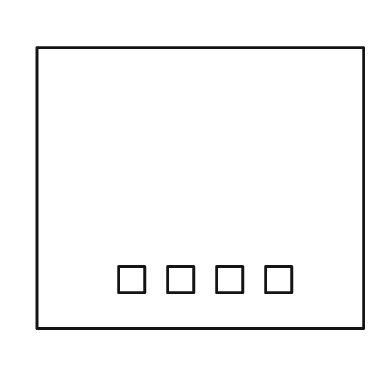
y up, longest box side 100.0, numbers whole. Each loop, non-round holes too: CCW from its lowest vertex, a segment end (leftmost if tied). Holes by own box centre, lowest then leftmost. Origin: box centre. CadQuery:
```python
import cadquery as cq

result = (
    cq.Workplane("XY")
    .moveTo(-50.0, -43.0)
    .lineTo(50.0, -43.0)
    .lineTo(50.0, 43.0)
    .lineTo(-50.0, 43.0)
    .close()
    .moveTo(-25.0, -32.0)
    .lineTo(-17.0, -32.0)
    .lineTo(-17.0, -24.0)
    .lineTo(-25.0, -24.0)
    .close()
    .moveTo(-10.0, -32.0)
    .lineTo(-2.0, -32.0)
    .lineTo(-2.0, -24.0)
    .lineTo(-10.0, -24.0)
    .close()
    .moveTo(5.0, -32.0)
    .lineTo(13.0, -32.0)
    .lineTo(13.0, -24.0)
    .lineTo(5.0, -24.0)
    .close()
    .moveTo(20.0, -32.0)
    .lineTo(28.0, -32.0)
    .lineTo(28.0, -24.0)
    .lineTo(20.0, -24.0)
    .close()
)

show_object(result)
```